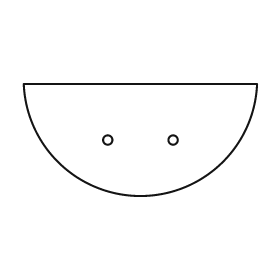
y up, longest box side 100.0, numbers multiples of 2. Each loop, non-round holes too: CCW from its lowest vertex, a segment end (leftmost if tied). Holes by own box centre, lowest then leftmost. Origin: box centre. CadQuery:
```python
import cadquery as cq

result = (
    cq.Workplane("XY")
    .moveTo(-50.0, 24.0)
    .threePointArc((0.0, -24.0), (50.0, 24.0))
    .close()
    .moveTo(-14.0, 0.0)
    .circle(2.0)
    .moveTo(14.0, 0.0)
    .circle(2.0)
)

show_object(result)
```